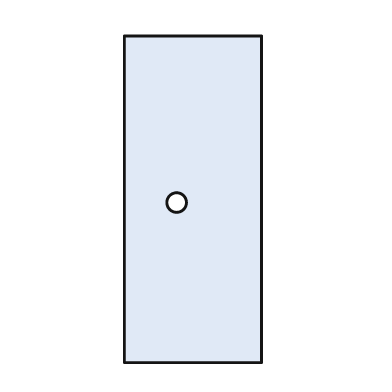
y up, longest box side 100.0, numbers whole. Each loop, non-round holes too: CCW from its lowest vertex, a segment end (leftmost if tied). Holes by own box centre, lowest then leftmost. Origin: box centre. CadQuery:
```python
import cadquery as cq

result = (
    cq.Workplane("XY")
    .moveTo(-21.0, -50.0)
    .lineTo(21.0, -50.0)
    .lineTo(21.0, 50.0)
    .lineTo(-21.0, 50.0)
    .close()
    .moveTo(-5.0, -1.0)
    .circle(3.0)
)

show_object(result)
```